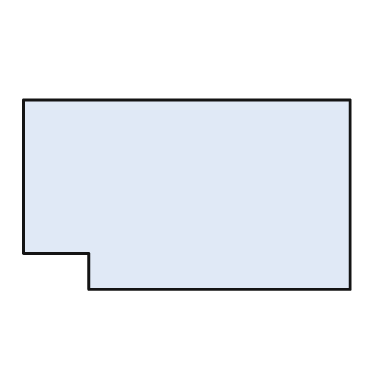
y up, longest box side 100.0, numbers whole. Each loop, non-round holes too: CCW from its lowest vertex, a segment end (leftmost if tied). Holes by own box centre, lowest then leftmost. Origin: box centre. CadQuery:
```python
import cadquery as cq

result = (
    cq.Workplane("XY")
    .moveTo(-30.0, -29.0)
    .lineTo(50.0, -29.0)
    .lineTo(50.0, 29.0)
    .lineTo(-50.0, 29.0)
    .lineTo(-50.0, -18.0)
    .lineTo(-30.0, -18.0)
    .close()
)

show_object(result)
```